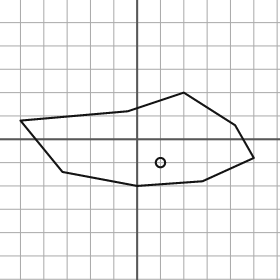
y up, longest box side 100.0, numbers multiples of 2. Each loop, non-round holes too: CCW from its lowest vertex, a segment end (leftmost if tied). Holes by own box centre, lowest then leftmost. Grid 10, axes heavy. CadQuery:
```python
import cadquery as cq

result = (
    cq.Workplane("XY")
    .moveTo(0.0, -20.0)
    .lineTo(28.0, -18.0)
    .lineTo(50.0, -8.0)
    .lineTo(42.0, 6.0)
    .lineTo(20.0, 20.0)
    .lineTo(-4.0, 12.0)
    .lineTo(-50.0, 8.0)
    .lineTo(-32.0, -14.0)
    .close()
    .moveTo(10.0, -10.0)
    .circle(2.0)
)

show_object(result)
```